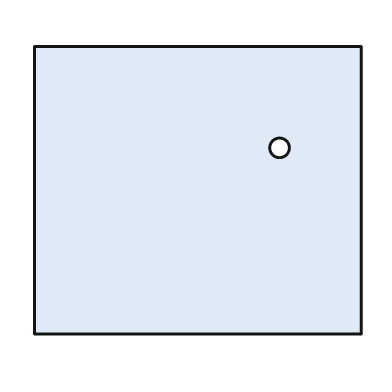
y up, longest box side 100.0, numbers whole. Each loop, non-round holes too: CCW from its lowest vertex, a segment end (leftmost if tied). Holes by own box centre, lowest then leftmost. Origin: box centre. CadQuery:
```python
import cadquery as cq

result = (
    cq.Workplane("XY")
    .moveTo(-50.0, -44.0)
    .lineTo(50.0, -44.0)
    .lineTo(50.0, 44.0)
    .lineTo(-50.0, 44.0)
    .close()
    .moveTo(25.0, 13.0)
    .circle(3.0)
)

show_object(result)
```